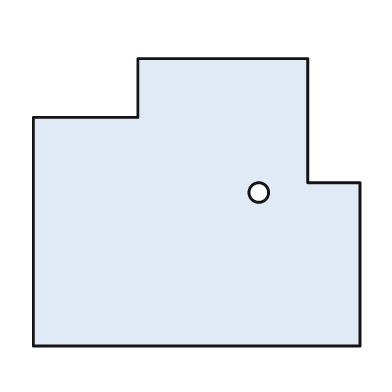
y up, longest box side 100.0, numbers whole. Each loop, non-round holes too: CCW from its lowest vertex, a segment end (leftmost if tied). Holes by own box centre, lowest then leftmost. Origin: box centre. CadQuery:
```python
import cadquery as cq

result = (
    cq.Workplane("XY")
    .moveTo(-50.0, -44.0)
    .lineTo(50.0, -44.0)
    .lineTo(50.0, 6.0)
    .lineTo(34.0, 6.0)
    .lineTo(34.0, 44.0)
    .lineTo(-18.0, 44.0)
    .lineTo(-18.0, 26.0)
    .lineTo(-50.0, 26.0)
    .close()
    .moveTo(19.0, 3.0)
    .circle(3.0)
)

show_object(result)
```